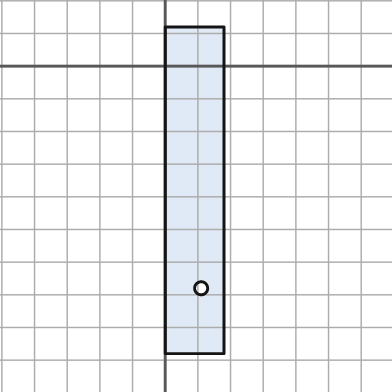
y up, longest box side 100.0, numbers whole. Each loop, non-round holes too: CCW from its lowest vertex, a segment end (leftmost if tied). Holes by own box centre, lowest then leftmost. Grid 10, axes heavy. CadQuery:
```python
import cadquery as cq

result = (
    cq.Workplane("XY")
    .moveTo(0.0, -88.0)
    .lineTo(18.0, -88.0)
    .lineTo(18.0, 12.0)
    .lineTo(0.0, 12.0)
    .close()
    .moveTo(11.0, -68.0)
    .circle(2.0)
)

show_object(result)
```